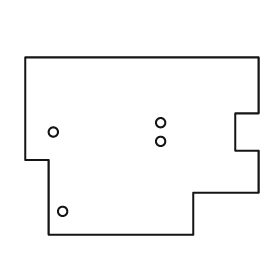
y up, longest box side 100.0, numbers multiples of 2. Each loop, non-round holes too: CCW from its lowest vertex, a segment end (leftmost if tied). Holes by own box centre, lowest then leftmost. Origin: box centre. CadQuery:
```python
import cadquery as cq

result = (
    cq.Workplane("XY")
    .moveTo(-40.0, -38.0)
    .lineTo(22.0, -38.0)
    .lineTo(22.0, -20.0)
    .lineTo(50.0, -20.0)
    .lineTo(50.0, -2.0)
    .lineTo(40.0, -2.0)
    .lineTo(40.0, 14.0)
    .lineTo(50.0, 14.0)
    .lineTo(50.0, 38.0)
    .lineTo(-50.0, 38.0)
    .lineTo(-50.0, -6.0)
    .lineTo(-40.0, -6.0)
    .close()
    .moveTo(-34.0, -28.0)
    .circle(2.0)
    .moveTo(8.0, 2.0)
    .circle(2.0)
    .moveTo(-38.0, 6.0)
    .circle(2.0)
    .moveTo(8.0, 10.0)
    .circle(2.0)
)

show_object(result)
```